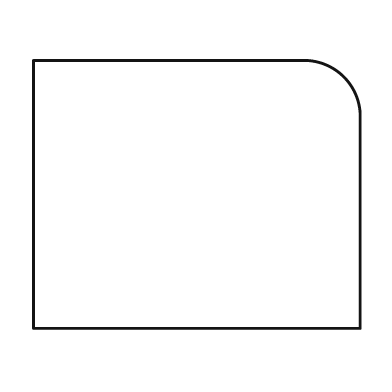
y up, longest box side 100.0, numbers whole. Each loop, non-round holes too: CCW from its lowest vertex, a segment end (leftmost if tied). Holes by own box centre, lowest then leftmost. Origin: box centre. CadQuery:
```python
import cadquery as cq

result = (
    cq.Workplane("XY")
    .moveTo(-50.0, -41.0)
    .lineTo(50.0, -41.0)
    .lineTo(50.0, 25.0)
    .threePointArc((45.0, 36.0), (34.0, 41.0))
    .lineTo(-50.0, 41.0)
    .close()
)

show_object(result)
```